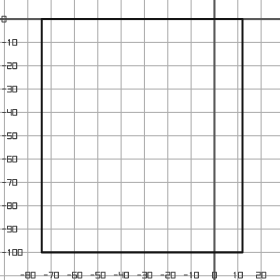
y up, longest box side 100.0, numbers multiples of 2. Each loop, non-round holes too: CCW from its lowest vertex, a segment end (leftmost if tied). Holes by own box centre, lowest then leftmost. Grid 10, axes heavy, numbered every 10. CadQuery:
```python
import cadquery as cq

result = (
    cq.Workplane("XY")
    .moveTo(-74.0, -100.0)
    .lineTo(12.0, -100.0)
    .lineTo(12.0, 0.0)
    .lineTo(-74.0, 0.0)
    .close()
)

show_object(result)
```